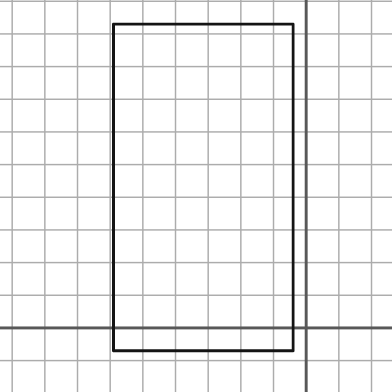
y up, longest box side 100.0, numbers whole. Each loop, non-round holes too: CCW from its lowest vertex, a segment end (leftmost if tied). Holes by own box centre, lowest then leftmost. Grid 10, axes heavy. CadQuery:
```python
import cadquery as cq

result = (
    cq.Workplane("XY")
    .moveTo(-59.0, -7.0)
    .lineTo(-4.0, -7.0)
    .lineTo(-4.0, 93.0)
    .lineTo(-59.0, 93.0)
    .close()
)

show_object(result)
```